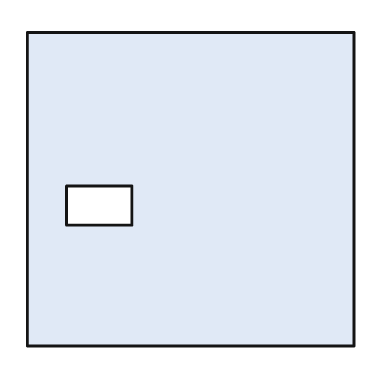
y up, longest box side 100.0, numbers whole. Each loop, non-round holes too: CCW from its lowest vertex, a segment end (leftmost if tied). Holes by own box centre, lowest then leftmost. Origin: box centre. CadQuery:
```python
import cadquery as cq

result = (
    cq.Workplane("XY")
    .moveTo(-50.0, -48.0)
    .lineTo(50.0, -48.0)
    .lineTo(50.0, 48.0)
    .lineTo(-50.0, 48.0)
    .close()
    .moveTo(-38.0, -11.0)
    .lineTo(-18.0, -11.0)
    .lineTo(-18.0, 1.0)
    .lineTo(-38.0, 1.0)
    .close()
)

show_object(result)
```